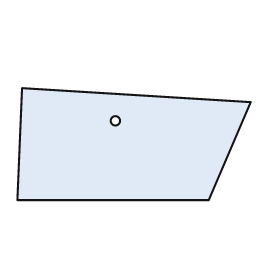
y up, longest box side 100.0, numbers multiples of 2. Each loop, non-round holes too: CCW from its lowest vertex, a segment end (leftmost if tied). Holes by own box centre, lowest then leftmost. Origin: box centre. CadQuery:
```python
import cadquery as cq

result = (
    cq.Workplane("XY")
    .moveTo(-50.0, -24.0)
    .lineTo(32.0, -24.0)
    .lineTo(50.0, 18.0)
    .lineTo(-48.0, 24.0)
    .close()
    .moveTo(-8.0, 10.0)
    .circle(2.0)
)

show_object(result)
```